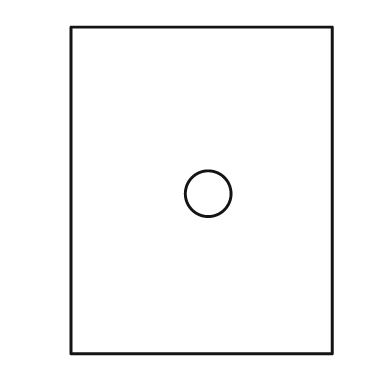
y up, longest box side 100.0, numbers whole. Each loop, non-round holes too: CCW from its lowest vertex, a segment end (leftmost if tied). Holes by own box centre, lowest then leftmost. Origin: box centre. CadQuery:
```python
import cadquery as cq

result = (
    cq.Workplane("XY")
    .moveTo(-40.0, -50.0)
    .lineTo(40.0, -50.0)
    .lineTo(40.0, 50.0)
    .lineTo(-40.0, 50.0)
    .close()
    .moveTo(2.0, -1.0)
    .circle(7.0)
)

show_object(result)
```